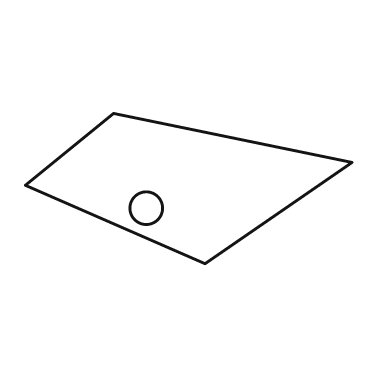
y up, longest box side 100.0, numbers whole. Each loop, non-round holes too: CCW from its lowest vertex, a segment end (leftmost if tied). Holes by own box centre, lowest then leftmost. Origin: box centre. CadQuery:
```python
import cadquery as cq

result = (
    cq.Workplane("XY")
    .moveTo(5.0, -23.0)
    .lineTo(50.0, 8.0)
    .lineTo(-23.0, 23.0)
    .lineTo(-50.0, 1.0)
    .close()
    .moveTo(-13.0, -6.0)
    .circle(5.0)
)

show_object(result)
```